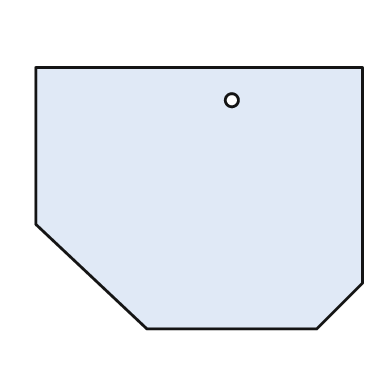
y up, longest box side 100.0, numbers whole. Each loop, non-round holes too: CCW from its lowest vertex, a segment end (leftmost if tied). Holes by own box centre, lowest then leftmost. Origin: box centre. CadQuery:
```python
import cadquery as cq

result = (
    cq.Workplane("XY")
    .moveTo(-16.0, -40.0)
    .lineTo(36.0, -40.0)
    .lineTo(50.0, -26.0)
    .lineTo(50.0, 40.0)
    .lineTo(-50.0, 40.0)
    .lineTo(-50.0, -8.0)
    .close()
    .moveTo(10.0, 30.0)
    .circle(2.0)
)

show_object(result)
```